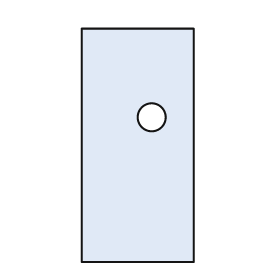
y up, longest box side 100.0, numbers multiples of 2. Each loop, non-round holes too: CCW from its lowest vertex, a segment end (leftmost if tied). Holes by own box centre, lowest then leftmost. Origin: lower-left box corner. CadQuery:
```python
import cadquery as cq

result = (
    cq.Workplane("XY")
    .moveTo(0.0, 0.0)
    .lineTo(48.0, 0.0)
    .lineTo(48.0, 100.0)
    .lineTo(0.0, 100.0)
    .close()
    .moveTo(30.0, 62.0)
    .circle(6.0)
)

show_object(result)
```